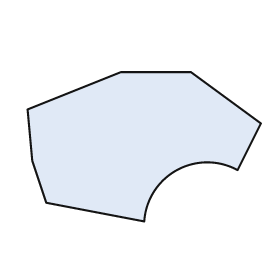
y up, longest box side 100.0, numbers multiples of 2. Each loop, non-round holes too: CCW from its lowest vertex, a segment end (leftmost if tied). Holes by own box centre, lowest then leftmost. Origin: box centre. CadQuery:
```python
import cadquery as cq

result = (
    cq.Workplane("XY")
    .moveTo(0.0, -32.0)
    .threePointArc((14.0, -10.0), (40.0, -10.0))
    .lineTo(50.0, 10.0)
    .lineTo(20.0, 32.0)
    .lineTo(-10.0, 32.0)
    .lineTo(-50.0, 16.0)
    .lineTo(-48.0, -6.0)
    .lineTo(-42.0, -24.0)
    .close()
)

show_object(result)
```